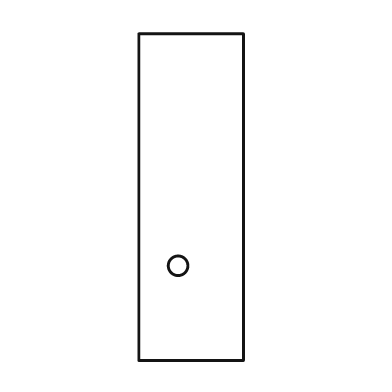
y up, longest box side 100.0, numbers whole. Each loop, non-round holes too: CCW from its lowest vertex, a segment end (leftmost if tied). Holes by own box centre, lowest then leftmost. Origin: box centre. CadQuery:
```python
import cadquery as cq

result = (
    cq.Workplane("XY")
    .moveTo(-16.0, -50.0)
    .lineTo(16.0, -50.0)
    .lineTo(16.0, 50.0)
    .lineTo(-16.0, 50.0)
    .close()
    .moveTo(-4.0, -21.0)
    .circle(3.0)
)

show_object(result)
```